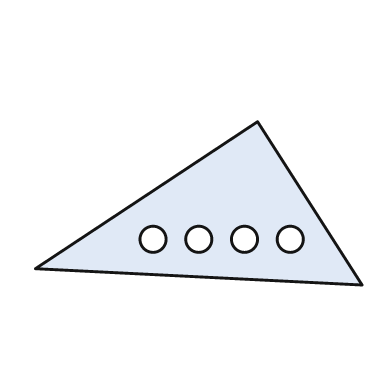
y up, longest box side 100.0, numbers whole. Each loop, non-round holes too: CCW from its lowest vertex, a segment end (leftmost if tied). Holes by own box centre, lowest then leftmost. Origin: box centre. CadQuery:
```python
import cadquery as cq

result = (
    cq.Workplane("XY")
    .moveTo(50.0, -25.0)
    .lineTo(18.0, 25.0)
    .lineTo(-50.0, -20.0)
    .close()
    .moveTo(-14.0, -11.0)
    .circle(4.0)
    .moveTo(0.0, -11.0)
    .circle(4.0)
    .moveTo(14.0, -11.0)
    .circle(4.0)
    .moveTo(28.0, -11.0)
    .circle(4.0)
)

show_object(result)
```